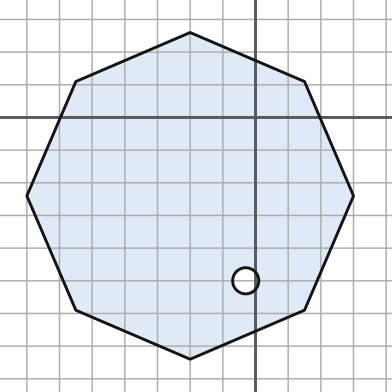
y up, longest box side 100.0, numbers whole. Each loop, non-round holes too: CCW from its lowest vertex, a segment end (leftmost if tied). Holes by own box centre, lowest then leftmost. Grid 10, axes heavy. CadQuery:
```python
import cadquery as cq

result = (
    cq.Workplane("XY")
    .moveTo(-20.0, -74.0)
    .lineTo(15.0, -59.0)
    .lineTo(30.0, -24.0)
    .lineTo(15.0, 11.0)
    .lineTo(-20.0, 26.0)
    .lineTo(-55.0, 11.0)
    .lineTo(-70.0, -24.0)
    .lineTo(-55.0, -59.0)
    .close()
    .moveTo(-3.0, -50.0)
    .circle(4.0)
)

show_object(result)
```